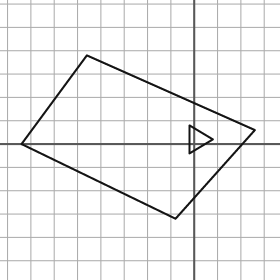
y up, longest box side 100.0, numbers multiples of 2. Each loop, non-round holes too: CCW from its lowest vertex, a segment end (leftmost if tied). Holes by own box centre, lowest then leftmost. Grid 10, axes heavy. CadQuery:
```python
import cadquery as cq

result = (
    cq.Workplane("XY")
    .moveTo(-8.0, -32.0)
    .lineTo(26.0, 6.0)
    .lineTo(-46.0, 38.0)
    .lineTo(-74.0, 0.0)
    .close()
    .moveTo(-2.0, -4.0)
    .lineTo(8.0, 2.0)
    .lineTo(-2.0, 8.0)
    .close()
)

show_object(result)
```